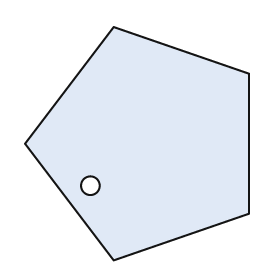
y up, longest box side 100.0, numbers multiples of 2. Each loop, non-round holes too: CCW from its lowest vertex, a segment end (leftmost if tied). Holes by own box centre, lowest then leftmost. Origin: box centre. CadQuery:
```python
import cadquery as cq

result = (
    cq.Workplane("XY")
    .moveTo(-10.0, -50.0)
    .lineTo(48.0, -30.0)
    .lineTo(48.0, 30.0)
    .lineTo(-10.0, 50.0)
    .lineTo(-48.0, 0.0)
    .close()
    .moveTo(-20.0, -18.0)
    .circle(4.0)
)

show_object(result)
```